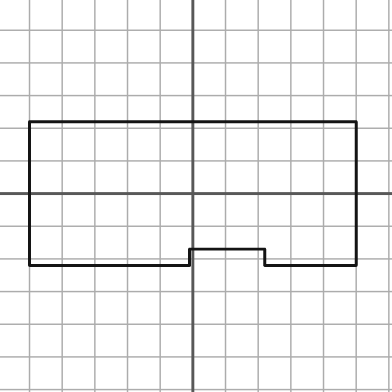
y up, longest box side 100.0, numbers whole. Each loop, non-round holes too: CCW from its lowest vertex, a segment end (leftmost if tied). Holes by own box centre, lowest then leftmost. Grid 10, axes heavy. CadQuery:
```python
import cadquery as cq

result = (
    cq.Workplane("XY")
    .moveTo(-50.0, -22.0)
    .lineTo(-1.0, -22.0)
    .lineTo(-1.0, -17.0)
    .lineTo(22.0, -17.0)
    .lineTo(22.0, -22.0)
    .lineTo(50.0, -22.0)
    .lineTo(50.0, 22.0)
    .lineTo(-50.0, 22.0)
    .close()
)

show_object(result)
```